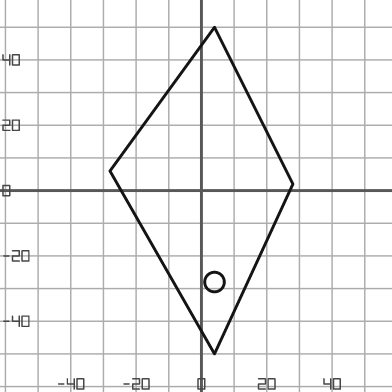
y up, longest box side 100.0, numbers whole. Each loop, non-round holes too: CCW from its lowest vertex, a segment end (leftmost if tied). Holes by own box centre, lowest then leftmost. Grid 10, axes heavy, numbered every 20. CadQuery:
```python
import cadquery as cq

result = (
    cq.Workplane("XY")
    .moveTo(4.0, -50.0)
    .lineTo(28.0, 2.0)
    .lineTo(4.0, 50.0)
    .lineTo(-28.0, 6.0)
    .close()
    .moveTo(4.0, -28.0)
    .circle(3.0)
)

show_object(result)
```